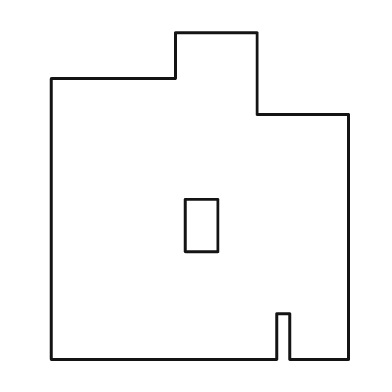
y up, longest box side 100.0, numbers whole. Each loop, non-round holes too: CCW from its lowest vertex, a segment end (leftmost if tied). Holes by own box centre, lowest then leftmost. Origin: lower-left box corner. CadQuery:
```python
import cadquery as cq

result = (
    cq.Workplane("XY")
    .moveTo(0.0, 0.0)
    .lineTo(69.0, 0.0)
    .lineTo(69.0, 14.0)
    .lineTo(73.0, 14.0)
    .lineTo(73.0, 0.0)
    .lineTo(91.0, 0.0)
    .lineTo(91.0, 75.0)
    .lineTo(63.0, 75.0)
    .lineTo(63.0, 100.0)
    .lineTo(38.0, 100.0)
    .lineTo(38.0, 86.0)
    .lineTo(0.0, 86.0)
    .close()
    .moveTo(41.0, 33.0)
    .lineTo(51.0, 33.0)
    .lineTo(51.0, 49.0)
    .lineTo(41.0, 49.0)
    .close()
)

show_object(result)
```